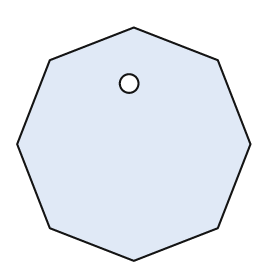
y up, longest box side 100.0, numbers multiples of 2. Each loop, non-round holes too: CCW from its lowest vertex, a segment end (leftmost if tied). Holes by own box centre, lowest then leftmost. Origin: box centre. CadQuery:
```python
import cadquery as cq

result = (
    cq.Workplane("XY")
    .moveTo(0.0, -50.0)
    .lineTo(36.0, -36.0)
    .lineTo(50.0, 0.0)
    .lineTo(36.0, 36.0)
    .lineTo(0.0, 50.0)
    .lineTo(-36.0, 36.0)
    .lineTo(-50.0, 0.0)
    .lineTo(-36.0, -36.0)
    .close()
    .moveTo(-2.0, 26.0)
    .circle(4.0)
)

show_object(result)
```